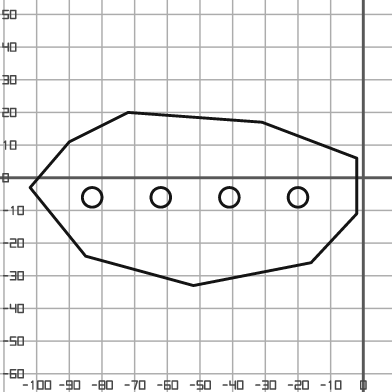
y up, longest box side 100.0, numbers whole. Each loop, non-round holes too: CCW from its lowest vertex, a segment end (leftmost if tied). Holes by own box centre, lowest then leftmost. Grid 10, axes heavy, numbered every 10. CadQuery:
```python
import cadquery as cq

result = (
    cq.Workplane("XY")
    .moveTo(-52.0, -33.0)
    .lineTo(-16.0, -26.0)
    .lineTo(-2.0, -11.0)
    .lineTo(-2.0, 6.0)
    .lineTo(-31.0, 17.0)
    .lineTo(-72.0, 20.0)
    .lineTo(-90.0, 11.0)
    .lineTo(-102.0, -3.0)
    .lineTo(-85.0, -24.0)
    .close()
    .moveTo(-83.0, -6.0)
    .circle(3.0)
    .moveTo(-62.0, -6.0)
    .circle(3.0)
    .moveTo(-41.0, -6.0)
    .circle(3.0)
    .moveTo(-20.0, -6.0)
    .circle(3.0)
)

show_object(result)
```